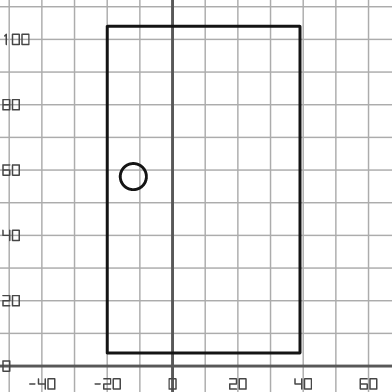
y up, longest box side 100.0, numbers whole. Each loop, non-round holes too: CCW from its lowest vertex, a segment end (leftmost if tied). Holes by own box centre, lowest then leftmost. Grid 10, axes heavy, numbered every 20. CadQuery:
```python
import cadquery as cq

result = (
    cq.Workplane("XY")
    .moveTo(-20.0, 4.0)
    .lineTo(39.0, 4.0)
    .lineTo(39.0, 104.0)
    .lineTo(-20.0, 104.0)
    .close()
    .moveTo(-12.0, 58.0)
    .circle(4.0)
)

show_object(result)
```